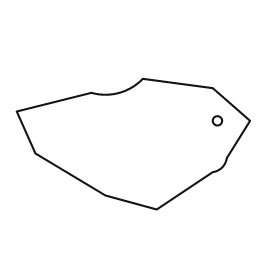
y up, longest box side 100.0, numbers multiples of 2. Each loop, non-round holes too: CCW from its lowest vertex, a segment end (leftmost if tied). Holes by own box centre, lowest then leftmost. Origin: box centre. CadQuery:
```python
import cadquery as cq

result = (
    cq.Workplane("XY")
    .moveTo(10.0, -28.0)
    .lineTo(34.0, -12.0)
    .threePointArc((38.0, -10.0), (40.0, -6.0))
    .lineTo(50.0, 10.0)
    .lineTo(34.0, 24.0)
    .lineTo(4.0, 28.0)
    .threePointArc((-6.0, 22.0), (-18.0, 22.0))
    .lineTo(-50.0, 14.0)
    .lineTo(-42.0, -4.0)
    .lineTo(-12.0, -22.0)
    .close()
    .moveTo(36.0, 10.0)
    .circle(2.0)
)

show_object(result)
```